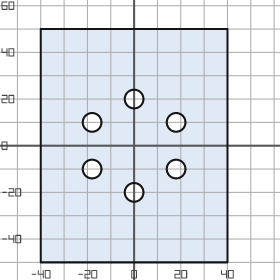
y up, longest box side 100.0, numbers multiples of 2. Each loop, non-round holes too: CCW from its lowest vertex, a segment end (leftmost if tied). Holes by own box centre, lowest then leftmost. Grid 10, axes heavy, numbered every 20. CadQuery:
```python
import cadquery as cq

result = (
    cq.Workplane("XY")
    .moveTo(-40.0, -50.0)
    .lineTo(40.0, -50.0)
    .lineTo(40.0, 50.0)
    .lineTo(-40.0, 50.0)
    .close()
    .moveTo(0.0, -20.0)
    .circle(4.0)
    .moveTo(-18.0, -10.0)
    .circle(4.0)
    .moveTo(18.0, -10.0)
    .circle(4.0)
    .moveTo(-18.0, 10.0)
    .circle(4.0)
    .moveTo(18.0, 10.0)
    .circle(4.0)
    .moveTo(0.0, 20.0)
    .circle(4.0)
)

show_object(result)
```